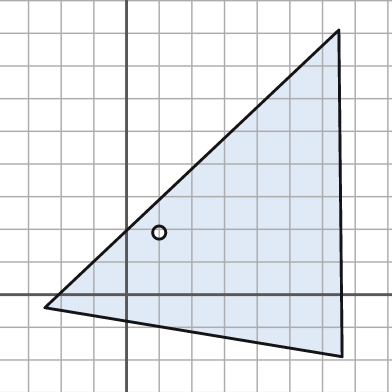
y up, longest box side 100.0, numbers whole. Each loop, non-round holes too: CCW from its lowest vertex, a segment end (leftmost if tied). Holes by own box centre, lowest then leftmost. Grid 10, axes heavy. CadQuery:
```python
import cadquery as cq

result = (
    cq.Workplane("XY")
    .moveTo(66.0, -19.0)
    .lineTo(65.0, 81.0)
    .lineTo(-25.0, -4.0)
    .close()
    .moveTo(10.0, 19.0)
    .circle(2.0)
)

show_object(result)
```